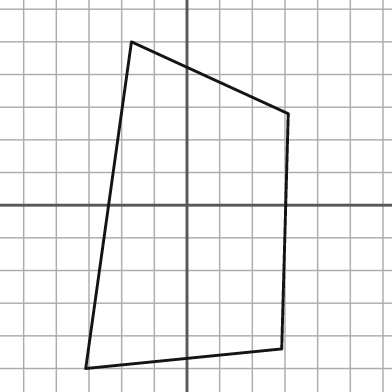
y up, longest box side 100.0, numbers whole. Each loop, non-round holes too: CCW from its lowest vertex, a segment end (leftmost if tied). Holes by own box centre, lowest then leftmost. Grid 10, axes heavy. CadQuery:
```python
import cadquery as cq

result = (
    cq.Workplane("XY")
    .moveTo(-31.0, -50.0)
    .lineTo(29.0, -44.0)
    .lineTo(31.0, 28.0)
    .lineTo(-17.0, 50.0)
    .close()
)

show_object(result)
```